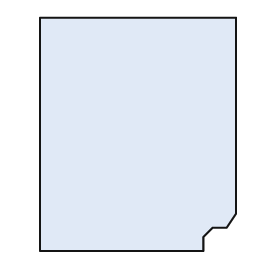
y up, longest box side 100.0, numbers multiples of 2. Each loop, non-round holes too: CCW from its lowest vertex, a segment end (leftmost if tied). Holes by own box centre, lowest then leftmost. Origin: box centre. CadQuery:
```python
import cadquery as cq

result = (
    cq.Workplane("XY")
    .moveTo(-42.0, -50.0)
    .lineTo(28.0, -50.0)
    .lineTo(28.0, -44.0)
    .lineTo(32.0, -40.0)
    .lineTo(38.0, -40.0)
    .lineTo(42.0, -34.0)
    .lineTo(42.0, 50.0)
    .lineTo(-42.0, 50.0)
    .close()
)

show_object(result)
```